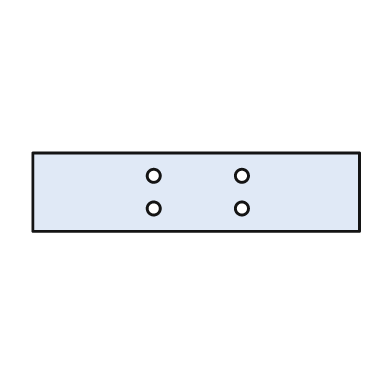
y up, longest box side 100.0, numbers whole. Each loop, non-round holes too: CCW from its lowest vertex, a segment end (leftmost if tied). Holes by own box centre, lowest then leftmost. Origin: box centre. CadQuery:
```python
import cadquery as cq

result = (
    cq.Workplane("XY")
    .moveTo(-50.0, -12.0)
    .lineTo(50.0, -12.0)
    .lineTo(50.0, 12.0)
    .lineTo(-50.0, 12.0)
    .close()
    .moveTo(-13.0, -5.0)
    .circle(2.0)
    .moveTo(14.0, -5.0)
    .circle(2.0)
    .moveTo(-13.0, 5.0)
    .circle(2.0)
    .moveTo(14.0, 5.0)
    .circle(2.0)
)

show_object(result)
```